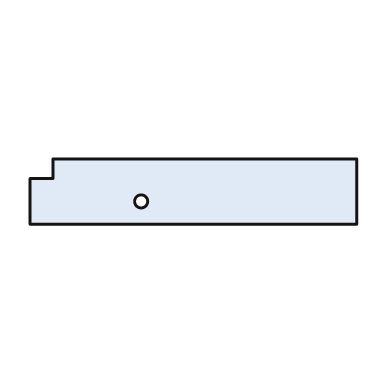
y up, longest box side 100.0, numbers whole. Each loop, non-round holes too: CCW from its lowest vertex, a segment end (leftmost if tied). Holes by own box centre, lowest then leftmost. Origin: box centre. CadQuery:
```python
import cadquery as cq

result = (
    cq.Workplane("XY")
    .moveTo(-50.0, -10.0)
    .lineTo(50.0, -10.0)
    .lineTo(50.0, 10.0)
    .lineTo(-43.0, 10.0)
    .lineTo(-43.0, 4.0)
    .lineTo(-50.0, 4.0)
    .close()
    .moveTo(-16.0, -3.0)
    .circle(2.0)
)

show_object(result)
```